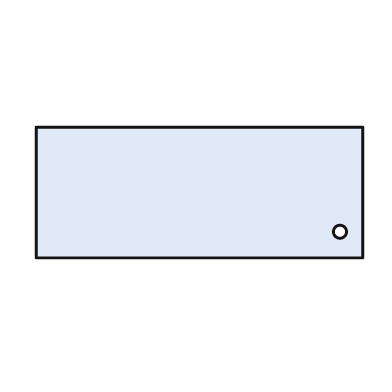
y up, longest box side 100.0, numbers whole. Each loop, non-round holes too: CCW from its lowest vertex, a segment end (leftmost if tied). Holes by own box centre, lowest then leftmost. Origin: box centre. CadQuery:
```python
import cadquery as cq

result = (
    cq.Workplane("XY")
    .moveTo(-50.0, -20.0)
    .lineTo(50.0, -20.0)
    .lineTo(50.0, 20.0)
    .lineTo(-50.0, 20.0)
    .close()
    .moveTo(43.0, -12.0)
    .circle(2.0)
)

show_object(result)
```